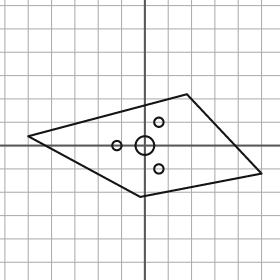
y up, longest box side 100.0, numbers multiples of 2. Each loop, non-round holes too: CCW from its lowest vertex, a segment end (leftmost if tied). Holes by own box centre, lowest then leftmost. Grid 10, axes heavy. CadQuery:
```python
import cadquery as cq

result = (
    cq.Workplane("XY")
    .moveTo(-2.0, -22.0)
    .lineTo(50.0, -12.0)
    .lineTo(18.0, 22.0)
    .lineTo(-50.0, 4.0)
    .close()
    .moveTo(6.0, -10.0)
    .circle(2.0)
    .moveTo(-12.0, 0.0)
    .circle(2.0)
    .moveTo(0.0, 0.0)
    .circle(4.0)
    .moveTo(6.0, 10.0)
    .circle(2.0)
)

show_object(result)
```